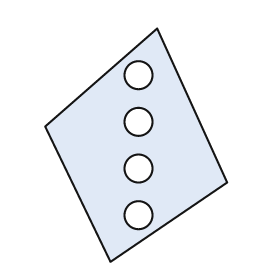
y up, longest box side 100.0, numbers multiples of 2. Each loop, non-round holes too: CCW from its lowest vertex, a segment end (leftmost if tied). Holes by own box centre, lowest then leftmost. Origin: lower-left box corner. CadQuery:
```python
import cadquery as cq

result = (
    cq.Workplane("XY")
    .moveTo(28.0, 0.0)
    .lineTo(78.0, 34.0)
    .lineTo(48.0, 100.0)
    .lineTo(0.0, 58.0)
    .close()
    .moveTo(40.0, 20.0)
    .circle(6.0)
    .moveTo(40.0, 40.0)
    .circle(6.0)
    .moveTo(40.0, 60.0)
    .circle(6.0)
    .moveTo(40.0, 80.0)
    .circle(6.0)
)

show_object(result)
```